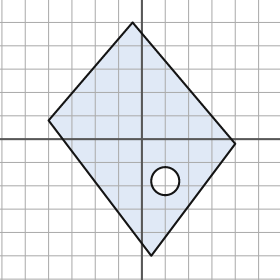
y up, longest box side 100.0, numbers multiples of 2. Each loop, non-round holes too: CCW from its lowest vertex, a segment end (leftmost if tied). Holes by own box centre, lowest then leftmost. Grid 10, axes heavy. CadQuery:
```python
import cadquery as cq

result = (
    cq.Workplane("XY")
    .moveTo(4.0, -50.0)
    .lineTo(40.0, -2.0)
    .lineTo(-4.0, 50.0)
    .lineTo(-40.0, 8.0)
    .close()
    .moveTo(10.0, -18.0)
    .circle(6.0)
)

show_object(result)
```